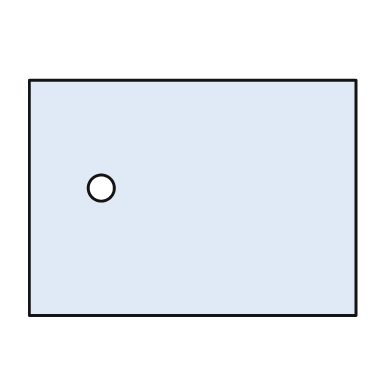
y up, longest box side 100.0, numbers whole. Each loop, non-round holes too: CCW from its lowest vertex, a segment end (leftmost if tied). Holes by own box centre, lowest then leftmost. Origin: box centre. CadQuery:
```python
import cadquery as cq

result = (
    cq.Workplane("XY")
    .moveTo(-50.0, -36.0)
    .lineTo(50.0, -36.0)
    .lineTo(50.0, 36.0)
    .lineTo(-50.0, 36.0)
    .close()
    .moveTo(-28.0, 3.0)
    .circle(4.0)
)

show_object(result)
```